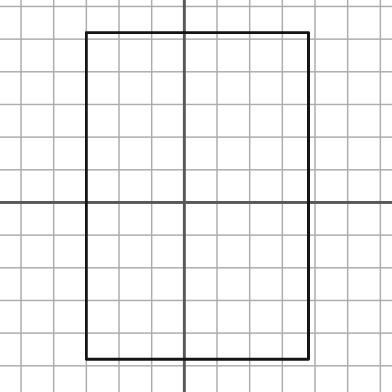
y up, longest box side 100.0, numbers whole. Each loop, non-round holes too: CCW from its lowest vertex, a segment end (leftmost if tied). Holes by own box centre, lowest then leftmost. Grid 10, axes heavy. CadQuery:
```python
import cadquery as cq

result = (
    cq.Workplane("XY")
    .moveTo(-30.0, -48.0)
    .lineTo(38.0, -48.0)
    .lineTo(38.0, 52.0)
    .lineTo(-30.0, 52.0)
    .close()
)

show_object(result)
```